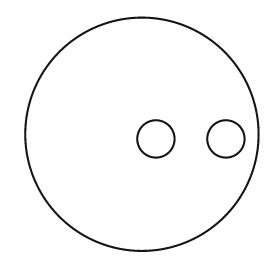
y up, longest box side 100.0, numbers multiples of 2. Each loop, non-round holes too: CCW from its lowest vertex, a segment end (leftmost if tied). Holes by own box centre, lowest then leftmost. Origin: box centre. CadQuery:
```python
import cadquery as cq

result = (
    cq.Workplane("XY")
    .moveTo(0.0, 0.0)
    .circle(50.0)
    .moveTo(6.0, -2.0)
    .circle(8.0)
    .moveTo(36.0, -2.0)
    .circle(8.0)
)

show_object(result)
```